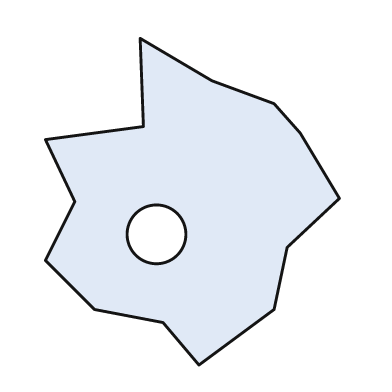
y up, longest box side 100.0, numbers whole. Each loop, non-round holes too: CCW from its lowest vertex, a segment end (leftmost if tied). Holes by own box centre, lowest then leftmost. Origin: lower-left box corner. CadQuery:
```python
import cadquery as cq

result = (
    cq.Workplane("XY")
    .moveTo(47.0, 0.0)
    .lineTo(70.0, 17.0)
    .lineTo(74.0, 36.0)
    .lineTo(90.0, 51.0)
    .lineTo(78.0, 71.0)
    .lineTo(70.0, 80.0)
    .lineTo(51.0, 87.0)
    .lineTo(29.0, 100.0)
    .lineTo(30.0, 73.0)
    .lineTo(0.0, 69.0)
    .lineTo(9.0, 50.0)
    .lineTo(0.0, 32.0)
    .lineTo(15.0, 17.0)
    .lineTo(36.0, 13.0)
    .close()
    .moveTo(34.0, 40.0)
    .circle(9.0)
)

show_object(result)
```